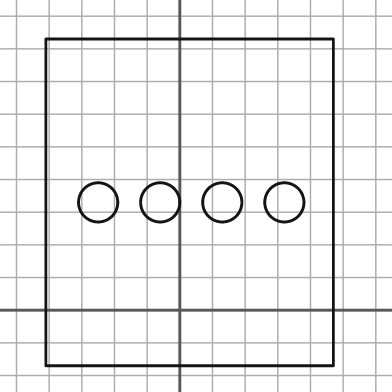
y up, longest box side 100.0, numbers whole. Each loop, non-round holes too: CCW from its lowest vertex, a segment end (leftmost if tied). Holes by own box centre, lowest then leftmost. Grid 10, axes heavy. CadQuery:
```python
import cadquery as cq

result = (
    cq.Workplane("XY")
    .moveTo(-41.0, -17.0)
    .lineTo(47.0, -17.0)
    .lineTo(47.0, 83.0)
    .lineTo(-41.0, 83.0)
    .close()
    .moveTo(-25.0, 33.0)
    .circle(6.0)
    .moveTo(-6.0, 33.0)
    .circle(6.0)
    .moveTo(13.0, 33.0)
    .circle(6.0)
    .moveTo(32.0, 33.0)
    .circle(6.0)
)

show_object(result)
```